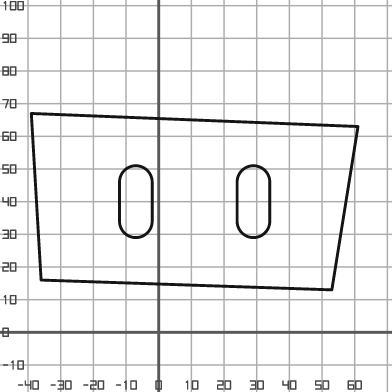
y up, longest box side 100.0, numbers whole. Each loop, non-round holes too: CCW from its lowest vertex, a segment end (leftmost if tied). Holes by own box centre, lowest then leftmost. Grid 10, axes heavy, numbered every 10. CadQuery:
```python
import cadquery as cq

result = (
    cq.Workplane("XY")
    .moveTo(53.0, 13.0)
    .lineTo(61.0, 63.0)
    .lineTo(-39.0, 67.0)
    .lineTo(-36.0, 16.0)
    .close()
    .moveTo(-12.0, 34.0)
    .threePointArc((-7.0, 29.0), (-2.0, 34.0))
    .lineTo(-2.0, 46.0)
    .threePointArc((-7.0, 51.0), (-12.0, 46.0))
    .close()
    .moveTo(24.0, 34.0)
    .threePointArc((29.0, 29.0), (34.0, 34.0))
    .lineTo(34.0, 46.0)
    .threePointArc((29.0, 51.0), (24.0, 46.0))
    .close()
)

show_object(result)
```